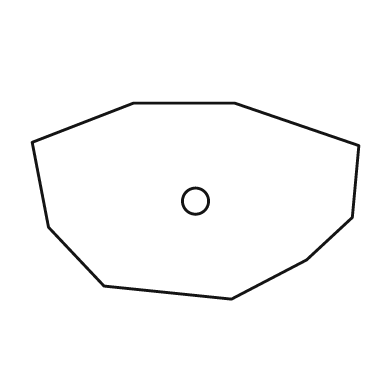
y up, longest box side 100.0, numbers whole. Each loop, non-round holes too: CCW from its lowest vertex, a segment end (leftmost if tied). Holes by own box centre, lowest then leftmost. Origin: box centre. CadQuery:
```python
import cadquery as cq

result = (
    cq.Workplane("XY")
    .moveTo(11.0, -30.0)
    .lineTo(34.0, -18.0)
    .lineTo(48.0, -5.0)
    .lineTo(50.0, 17.0)
    .lineTo(12.0, 30.0)
    .lineTo(-19.0, 30.0)
    .lineTo(-50.0, 18.0)
    .lineTo(-45.0, -8.0)
    .lineTo(-28.0, -26.0)
    .close()
    .moveTo(0.0, 0.0)
    .circle(4.0)
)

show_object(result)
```